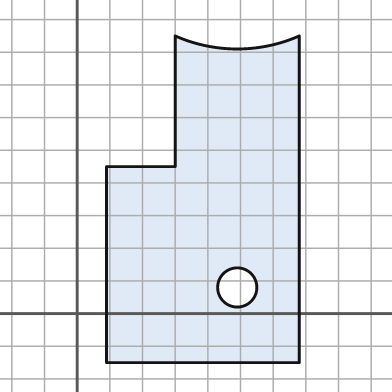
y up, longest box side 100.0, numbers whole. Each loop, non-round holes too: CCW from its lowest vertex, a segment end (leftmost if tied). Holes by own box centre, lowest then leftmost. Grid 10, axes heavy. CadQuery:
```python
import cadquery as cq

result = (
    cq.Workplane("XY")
    .moveTo(9.0, -15.0)
    .lineTo(68.0, -15.0)
    .lineTo(68.0, 85.0)
    .threePointArc((49.0, 81.0), (30.0, 85.0))
    .lineTo(30.0, 45.0)
    .lineTo(9.0, 45.0)
    .close()
    .moveTo(49.0, 8.0)
    .circle(6.0)
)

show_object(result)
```